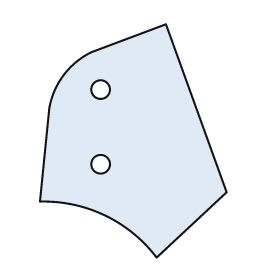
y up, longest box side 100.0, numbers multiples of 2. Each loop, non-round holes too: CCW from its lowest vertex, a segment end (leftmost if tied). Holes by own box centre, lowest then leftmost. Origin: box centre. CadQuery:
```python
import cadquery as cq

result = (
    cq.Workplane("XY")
    .moveTo(10.0, -50.0)
    .lineTo(40.0, -22.0)
    .lineTo(14.0, 50.0)
    .lineTo(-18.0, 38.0)
    .threePointArc((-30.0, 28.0), (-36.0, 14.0))
    .lineTo(-40.0, -26.0)
    .threePointArc((-12.0, -32.0), (10.0, -50.0))
    .close()
    .moveTo(-14.0, -10.0)
    .circle(4.0)
    .moveTo(-14.0, 22.0)
    .circle(4.0)
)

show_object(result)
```